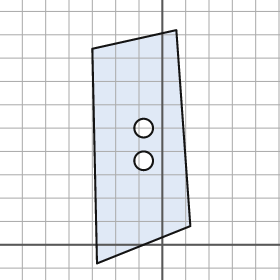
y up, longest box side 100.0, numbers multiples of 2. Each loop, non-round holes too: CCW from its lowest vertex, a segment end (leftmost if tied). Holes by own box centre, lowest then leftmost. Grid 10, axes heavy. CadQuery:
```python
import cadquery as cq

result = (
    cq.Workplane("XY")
    .moveTo(-28.0, -8.0)
    .lineTo(12.0, 8.0)
    .lineTo(6.0, 92.0)
    .lineTo(-30.0, 84.0)
    .close()
    .moveTo(-8.0, 36.0)
    .circle(4.0)
    .moveTo(-8.0, 50.0)
    .circle(4.0)
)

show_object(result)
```